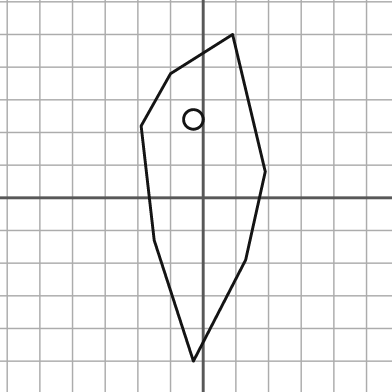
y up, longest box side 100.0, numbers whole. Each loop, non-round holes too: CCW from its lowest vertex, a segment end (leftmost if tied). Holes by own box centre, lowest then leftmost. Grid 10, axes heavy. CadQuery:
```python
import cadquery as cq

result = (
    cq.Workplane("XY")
    .moveTo(-3.0, -50.0)
    .lineTo(13.0, -19.0)
    .lineTo(19.0, 8.0)
    .lineTo(9.0, 50.0)
    .lineTo(-10.0, 38.0)
    .lineTo(-19.0, 22.0)
    .lineTo(-15.0, -13.0)
    .close()
    .moveTo(-3.0, 24.0)
    .circle(3.0)
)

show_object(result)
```